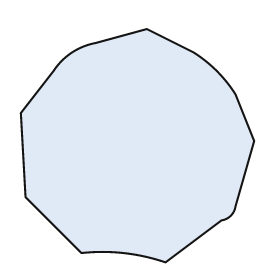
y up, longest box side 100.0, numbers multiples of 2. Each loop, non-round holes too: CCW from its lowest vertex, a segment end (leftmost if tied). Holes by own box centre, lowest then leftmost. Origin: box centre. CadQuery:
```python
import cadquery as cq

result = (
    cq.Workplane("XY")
    .moveTo(12.0, -50.0)
    .lineTo(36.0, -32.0)
    .threePointArc((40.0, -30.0), (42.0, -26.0))
    .lineTo(50.0, 2.0)
    .lineTo(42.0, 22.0)
    .threePointArc((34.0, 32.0), (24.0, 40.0))
    .lineTo(4.0, 50.0)
    .lineTo(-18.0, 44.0)
    .threePointArc((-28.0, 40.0), (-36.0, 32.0))
    .lineTo(-50.0, 14.0)
    .lineTo(-48.0, -22.0)
    .lineTo(-24.0, -46.0)
    .threePointArc((-6.0, -46.0), (12.0, -50.0))
    .close()
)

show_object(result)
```